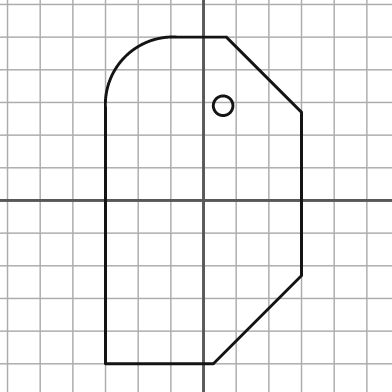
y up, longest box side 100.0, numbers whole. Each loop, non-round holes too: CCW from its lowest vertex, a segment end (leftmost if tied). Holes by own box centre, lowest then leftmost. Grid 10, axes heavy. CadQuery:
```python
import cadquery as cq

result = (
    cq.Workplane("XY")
    .moveTo(-30.0, -50.0)
    .lineTo(3.0, -50.0)
    .lineTo(30.0, -23.0)
    .lineTo(30.0, 27.0)
    .lineTo(7.0, 50.0)
    .lineTo(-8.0, 50.0)
    .threePointArc((-24.0, 44.0), (-30.0, 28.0))
    .close()
    .moveTo(6.0, 29.0)
    .circle(3.0)
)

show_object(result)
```